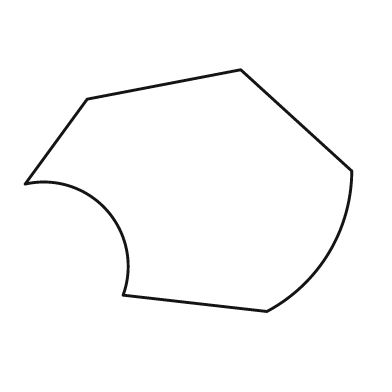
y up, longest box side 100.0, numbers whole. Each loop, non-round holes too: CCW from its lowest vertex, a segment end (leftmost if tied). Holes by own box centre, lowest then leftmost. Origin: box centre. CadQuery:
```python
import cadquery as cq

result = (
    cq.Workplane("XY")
    .moveTo(24.0, -37.0)
    .threePointArc((43.0, -19.0), (50.0, 6.0))
    .lineTo(16.0, 37.0)
    .lineTo(-31.0, 28.0)
    .lineTo(-50.0, 2.0)
    .threePointArc((-25.0, -6.0), (-20.0, -32.0))
    .close()
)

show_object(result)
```